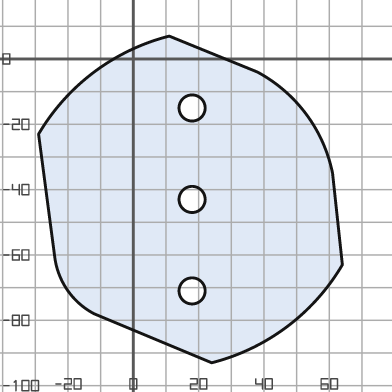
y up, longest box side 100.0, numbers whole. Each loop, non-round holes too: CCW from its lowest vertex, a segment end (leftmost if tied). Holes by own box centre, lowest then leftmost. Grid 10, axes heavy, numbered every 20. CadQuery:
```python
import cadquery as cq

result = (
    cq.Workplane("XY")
    .moveTo(24.0, -93.0)
    .threePointArc((47.0, -82.0), (64.0, -63.0))
    .lineTo(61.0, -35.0)
    .threePointArc((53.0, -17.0), (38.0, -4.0))
    .lineTo(11.0, 7.0)
    .threePointArc((-12.0, -4.0), (-29.0, -23.0))
    .lineTo(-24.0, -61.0)
    .threePointArc((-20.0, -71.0), (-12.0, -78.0))
    .close()
    .moveTo(18.0, -71.0)
    .circle(4.0)
    .moveTo(18.0, -43.0)
    .circle(4.0)
    .moveTo(18.0, -15.0)
    .circle(4.0)
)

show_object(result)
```